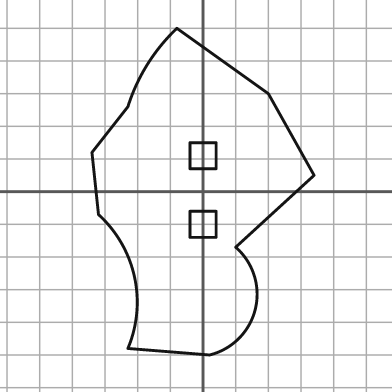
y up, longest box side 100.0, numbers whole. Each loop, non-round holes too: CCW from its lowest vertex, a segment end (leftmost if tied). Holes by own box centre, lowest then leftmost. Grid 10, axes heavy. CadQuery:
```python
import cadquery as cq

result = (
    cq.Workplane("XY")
    .moveTo(2.0, -50.0)
    .threePointArc((16.0, -36.0), (10.0, -17.0))
    .lineTo(34.0, 5.0)
    .lineTo(20.0, 30.0)
    .lineTo(-8.0, 50.0)
    .threePointArc((-17.0, 39.0), (-23.0, 26.0))
    .lineTo(-34.0, 12.0)
    .lineTo(-32.0, -7.0)
    .threePointArc((-21.0, -26.0), (-23.0, -48.0))
    .close()
    .moveTo(-4.0, -14.0)
    .lineTo(4.0, -14.0)
    .lineTo(4.0, -6.0)
    .lineTo(-4.0, -6.0)
    .close()
    .moveTo(-4.0, 7.0)
    .lineTo(4.0, 7.0)
    .lineTo(4.0, 15.0)
    .lineTo(-4.0, 15.0)
    .close()
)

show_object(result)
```